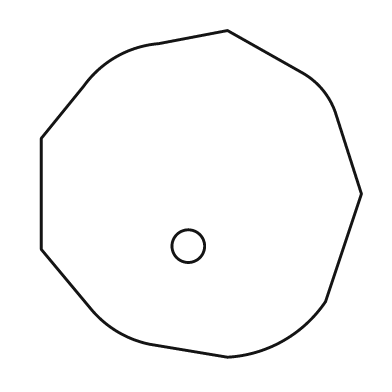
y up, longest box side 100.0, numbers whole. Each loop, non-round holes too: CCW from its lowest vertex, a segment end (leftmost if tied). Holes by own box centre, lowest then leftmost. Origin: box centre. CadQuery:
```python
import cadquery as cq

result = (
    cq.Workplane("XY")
    .moveTo(8.0, -50.0)
    .threePointArc((25.0, -45.0), (38.0, -33.0))
    .lineTo(49.0, 0.0)
    .lineTo(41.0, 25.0)
    .threePointArc((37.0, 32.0), (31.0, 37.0))
    .lineTo(8.0, 50.0)
    .lineTo(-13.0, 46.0)
    .threePointArc((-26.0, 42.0), (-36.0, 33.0))
    .lineTo(-49.0, 17.0)
    .lineTo(-49.0, -17.0)
    .lineTo(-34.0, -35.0)
    .threePointArc((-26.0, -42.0), (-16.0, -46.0))
    .close()
    .moveTo(-4.0, -16.0)
    .circle(5.0)
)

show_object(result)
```